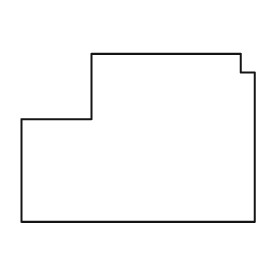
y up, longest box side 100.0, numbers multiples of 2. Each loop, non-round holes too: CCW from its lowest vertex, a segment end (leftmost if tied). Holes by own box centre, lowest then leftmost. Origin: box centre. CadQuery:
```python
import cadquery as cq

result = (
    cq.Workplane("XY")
    .moveTo(-50.0, -36.0)
    .lineTo(50.0, -36.0)
    .lineTo(50.0, 28.0)
    .lineTo(44.0, 28.0)
    .lineTo(44.0, 36.0)
    .lineTo(-20.0, 36.0)
    .lineTo(-20.0, 8.0)
    .lineTo(-50.0, 8.0)
    .close()
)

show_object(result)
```